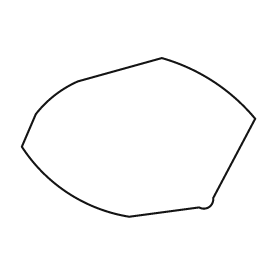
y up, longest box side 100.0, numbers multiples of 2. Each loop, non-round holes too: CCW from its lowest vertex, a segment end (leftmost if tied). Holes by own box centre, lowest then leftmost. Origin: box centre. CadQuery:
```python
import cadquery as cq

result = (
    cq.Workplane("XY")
    .moveTo(-4.0, -34.0)
    .lineTo(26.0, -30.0)
    .threePointArc((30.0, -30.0), (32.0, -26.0))
    .lineTo(50.0, 8.0)
    .threePointArc((32.0, 24.0), (10.0, 34.0))
    .lineTo(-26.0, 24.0)
    .threePointArc((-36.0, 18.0), (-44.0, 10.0))
    .lineTo(-50.0, -4.0)
    .threePointArc((-30.0, -24.0), (-4.0, -34.0))
    .close()
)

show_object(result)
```